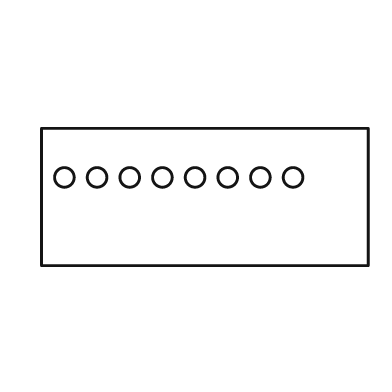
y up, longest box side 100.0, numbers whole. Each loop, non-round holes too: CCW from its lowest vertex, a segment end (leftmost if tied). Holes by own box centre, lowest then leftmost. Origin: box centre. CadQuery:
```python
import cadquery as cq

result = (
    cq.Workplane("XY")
    .moveTo(-50.0, -21.0)
    .lineTo(50.0, -21.0)
    .lineTo(50.0, 21.0)
    .lineTo(-50.0, 21.0)
    .close()
    .moveTo(-43.0, 6.0)
    .circle(3.0)
    .moveTo(-33.0, 6.0)
    .circle(3.0)
    .moveTo(-23.0, 6.0)
    .circle(3.0)
    .moveTo(-13.0, 6.0)
    .circle(3.0)
    .moveTo(-3.0, 6.0)
    .circle(3.0)
    .moveTo(7.0, 6.0)
    .circle(3.0)
    .moveTo(17.0, 6.0)
    .circle(3.0)
    .moveTo(27.0, 6.0)
    .circle(3.0)
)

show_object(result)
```